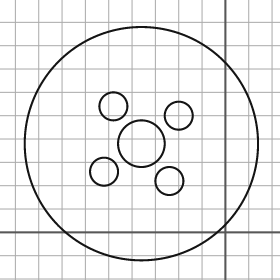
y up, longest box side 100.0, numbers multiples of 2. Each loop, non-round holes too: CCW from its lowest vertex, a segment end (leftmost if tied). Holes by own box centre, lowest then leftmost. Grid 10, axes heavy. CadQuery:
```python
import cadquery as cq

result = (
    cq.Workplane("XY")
    .moveTo(-36.0, 38.0)
    .circle(50.0)
    .moveTo(-24.0, 22.0)
    .circle(6.0)
    .moveTo(-52.0, 26.0)
    .circle(6.0)
    .moveTo(-36.0, 38.0)
    .circle(10.0)
    .moveTo(-20.0, 50.0)
    .circle(6.0)
    .moveTo(-48.0, 54.0)
    .circle(6.0)
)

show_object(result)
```